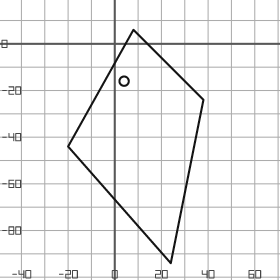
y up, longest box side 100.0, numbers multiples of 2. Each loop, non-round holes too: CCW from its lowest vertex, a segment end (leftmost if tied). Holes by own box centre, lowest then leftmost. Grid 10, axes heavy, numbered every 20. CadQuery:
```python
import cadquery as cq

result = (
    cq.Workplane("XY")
    .moveTo(24.0, -94.0)
    .lineTo(38.0, -24.0)
    .lineTo(8.0, 6.0)
    .lineTo(-20.0, -44.0)
    .close()
    .moveTo(4.0, -16.0)
    .circle(2.0)
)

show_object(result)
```